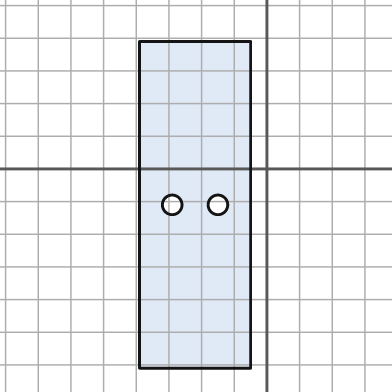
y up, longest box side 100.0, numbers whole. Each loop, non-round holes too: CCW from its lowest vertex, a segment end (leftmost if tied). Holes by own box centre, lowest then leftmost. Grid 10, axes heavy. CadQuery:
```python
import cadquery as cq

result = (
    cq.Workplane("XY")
    .moveTo(-39.0, -61.0)
    .lineTo(-5.0, -61.0)
    .lineTo(-5.0, 39.0)
    .lineTo(-39.0, 39.0)
    .close()
    .moveTo(-29.0, -11.0)
    .circle(3.0)
    .moveTo(-15.0, -11.0)
    .circle(3.0)
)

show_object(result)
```